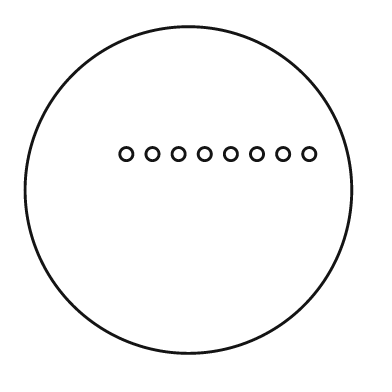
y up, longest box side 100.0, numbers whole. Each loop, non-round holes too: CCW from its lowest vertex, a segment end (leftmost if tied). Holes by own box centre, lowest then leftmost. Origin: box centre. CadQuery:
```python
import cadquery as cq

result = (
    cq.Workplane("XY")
    .moveTo(0.0, 0.0)
    .circle(50.0)
    .moveTo(-19.0, 11.0)
    .circle(2.0)
    .moveTo(-11.0, 11.0)
    .circle(2.0)
    .moveTo(-3.0, 11.0)
    .circle(2.0)
    .moveTo(5.0, 11.0)
    .circle(2.0)
    .moveTo(13.0, 11.0)
    .circle(2.0)
    .moveTo(21.0, 11.0)
    .circle(2.0)
    .moveTo(29.0, 11.0)
    .circle(2.0)
    .moveTo(37.0, 11.0)
    .circle(2.0)
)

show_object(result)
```